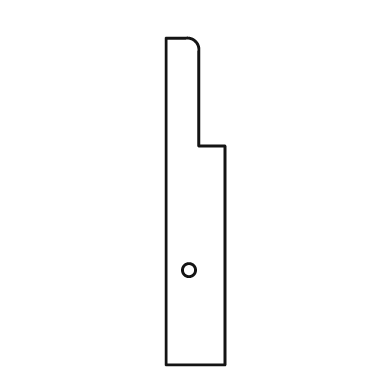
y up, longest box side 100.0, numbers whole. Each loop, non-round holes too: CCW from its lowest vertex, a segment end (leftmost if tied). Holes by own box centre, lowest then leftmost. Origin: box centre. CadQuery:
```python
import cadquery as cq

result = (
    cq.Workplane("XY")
    .moveTo(-9.0, -50.0)
    .lineTo(9.0, -50.0)
    .lineTo(9.0, 17.0)
    .lineTo(1.0, 17.0)
    .lineTo(1.0, 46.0)
    .threePointArc((0.0, 49.0), (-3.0, 50.0))
    .lineTo(-9.0, 50.0)
    .close()
    .moveTo(-2.0, -21.0)
    .circle(2.0)
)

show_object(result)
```